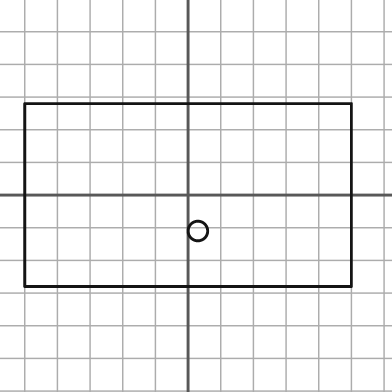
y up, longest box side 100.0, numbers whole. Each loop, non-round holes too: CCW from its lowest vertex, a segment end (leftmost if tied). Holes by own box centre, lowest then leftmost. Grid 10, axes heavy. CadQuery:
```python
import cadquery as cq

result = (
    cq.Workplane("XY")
    .moveTo(-50.0, -28.0)
    .lineTo(50.0, -28.0)
    .lineTo(50.0, 28.0)
    .lineTo(-50.0, 28.0)
    .close()
    .moveTo(3.0, -11.0)
    .circle(3.0)
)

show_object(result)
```